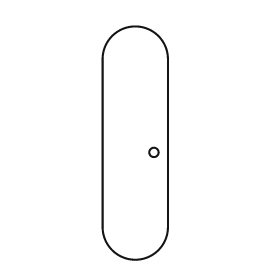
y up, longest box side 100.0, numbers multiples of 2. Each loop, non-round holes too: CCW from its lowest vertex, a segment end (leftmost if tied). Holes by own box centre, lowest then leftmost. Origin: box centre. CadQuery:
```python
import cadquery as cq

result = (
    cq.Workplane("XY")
    .moveTo(-14.0, -36.0)
    .threePointArc((0.0, -50.0), (14.0, -36.0))
    .lineTo(14.0, 36.0)
    .threePointArc((0.0, 50.0), (-14.0, 36.0))
    .close()
    .moveTo(8.0, -4.0)
    .circle(2.0)
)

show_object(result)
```